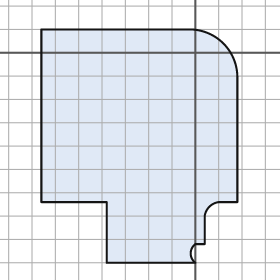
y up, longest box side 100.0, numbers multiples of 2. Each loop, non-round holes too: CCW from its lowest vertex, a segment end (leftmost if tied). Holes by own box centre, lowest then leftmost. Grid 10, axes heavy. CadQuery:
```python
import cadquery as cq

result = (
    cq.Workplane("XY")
    .moveTo(-38.0, -90.0)
    .lineTo(0.0, -90.0)
    .threePointArc((-2.0, -86.0), (0.0, -82.0))
    .lineTo(4.0, -82.0)
    .lineTo(4.0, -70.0)
    .threePointArc((6.0, -66.0), (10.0, -64.0))
    .lineTo(18.0, -64.0)
    .lineTo(18.0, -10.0)
    .threePointArc((12.0, 4.0), (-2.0, 10.0))
    .lineTo(-66.0, 10.0)
    .lineTo(-66.0, -64.0)
    .lineTo(-38.0, -64.0)
    .close()
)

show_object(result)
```